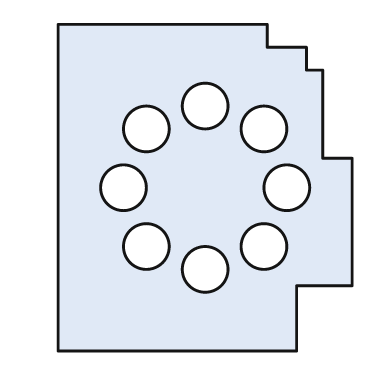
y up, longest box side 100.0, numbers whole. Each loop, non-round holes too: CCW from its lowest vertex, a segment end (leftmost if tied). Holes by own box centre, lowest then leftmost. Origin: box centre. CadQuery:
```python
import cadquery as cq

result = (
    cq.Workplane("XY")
    .moveTo(-45.0, -50.0)
    .lineTo(28.0, -50.0)
    .lineTo(28.0, -30.0)
    .lineTo(45.0, -30.0)
    .lineTo(45.0, 9.0)
    .lineTo(36.0, 9.0)
    .lineTo(36.0, 36.0)
    .lineTo(31.0, 36.0)
    .lineTo(31.0, 43.0)
    .lineTo(19.0, 43.0)
    .lineTo(19.0, 50.0)
    .lineTo(-45.0, 50.0)
    .close()
    .moveTo(0.0, -25.0)
    .circle(7.0)
    .moveTo(-18.0, -18.0)
    .circle(7.0)
    .moveTo(18.0, -18.0)
    .circle(7.0)
    .moveTo(-25.0, 0.0)
    .circle(7.0)
    .moveTo(25.0, 0.0)
    .circle(7.0)
    .moveTo(-18.0, 18.0)
    .circle(7.0)
    .moveTo(18.0, 18.0)
    .circle(7.0)
    .moveTo(0.0, 25.0)
    .circle(7.0)
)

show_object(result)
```